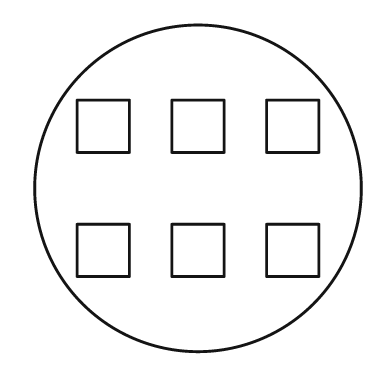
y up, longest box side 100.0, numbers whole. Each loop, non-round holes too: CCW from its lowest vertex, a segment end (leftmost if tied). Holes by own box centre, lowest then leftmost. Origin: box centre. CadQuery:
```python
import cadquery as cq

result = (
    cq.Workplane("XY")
    .moveTo(0.0, 0.0)
    .circle(50.0)
    .moveTo(-37.0, -27.0)
    .lineTo(-21.0, -27.0)
    .lineTo(-21.0, -11.0)
    .lineTo(-37.0, -11.0)
    .close()
    .moveTo(-8.0, -27.0)
    .lineTo(8.0, -27.0)
    .lineTo(8.0, -11.0)
    .lineTo(-8.0, -11.0)
    .close()
    .moveTo(21.0, -27.0)
    .lineTo(37.0, -27.0)
    .lineTo(37.0, -11.0)
    .lineTo(21.0, -11.0)
    .close()
    .moveTo(-37.0, 11.0)
    .lineTo(-21.0, 11.0)
    .lineTo(-21.0, 27.0)
    .lineTo(-37.0, 27.0)
    .close()
    .moveTo(-8.0, 11.0)
    .lineTo(8.0, 11.0)
    .lineTo(8.0, 27.0)
    .lineTo(-8.0, 27.0)
    .close()
    .moveTo(21.0, 11.0)
    .lineTo(37.0, 11.0)
    .lineTo(37.0, 27.0)
    .lineTo(21.0, 27.0)
    .close()
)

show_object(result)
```